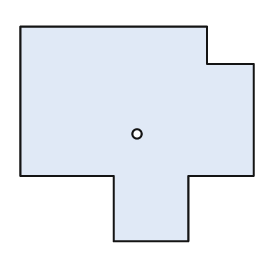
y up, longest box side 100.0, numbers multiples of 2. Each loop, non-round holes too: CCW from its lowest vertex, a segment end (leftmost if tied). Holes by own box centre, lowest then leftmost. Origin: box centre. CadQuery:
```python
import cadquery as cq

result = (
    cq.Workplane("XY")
    .moveTo(-10.0, -46.0)
    .lineTo(22.0, -46.0)
    .lineTo(22.0, -18.0)
    .lineTo(50.0, -18.0)
    .lineTo(50.0, 30.0)
    .lineTo(30.0, 30.0)
    .lineTo(30.0, 46.0)
    .lineTo(-50.0, 46.0)
    .lineTo(-50.0, -18.0)
    .lineTo(-10.0, -18.0)
    .close()
    .moveTo(0.0, 0.0)
    .circle(2.0)
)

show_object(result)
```